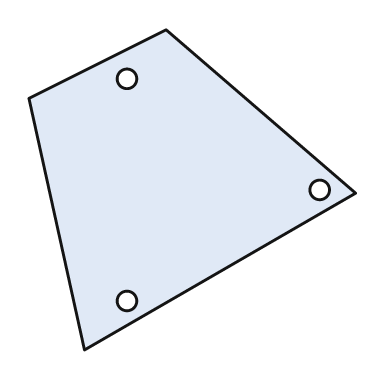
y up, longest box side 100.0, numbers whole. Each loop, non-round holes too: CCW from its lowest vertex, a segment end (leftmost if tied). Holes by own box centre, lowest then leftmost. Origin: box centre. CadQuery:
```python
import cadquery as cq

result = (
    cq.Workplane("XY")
    .moveTo(-33.0, -49.0)
    .lineTo(50.0, -1.0)
    .lineTo(-8.0, 49.0)
    .lineTo(-50.0, 28.0)
    .close()
    .moveTo(-20.0, -34.0)
    .circle(3.0)
    .moveTo(39.0, 0.0)
    .circle(3.0)
    .moveTo(-20.0, 34.0)
    .circle(3.0)
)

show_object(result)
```